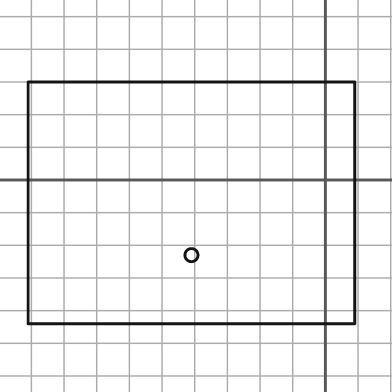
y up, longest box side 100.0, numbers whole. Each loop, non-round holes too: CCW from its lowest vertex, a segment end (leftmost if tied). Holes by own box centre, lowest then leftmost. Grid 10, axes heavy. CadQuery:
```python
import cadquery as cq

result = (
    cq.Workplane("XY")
    .moveTo(-91.0, -44.0)
    .lineTo(9.0, -44.0)
    .lineTo(9.0, 30.0)
    .lineTo(-91.0, 30.0)
    .close()
    .moveTo(-41.0, -23.0)
    .circle(2.0)
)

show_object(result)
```